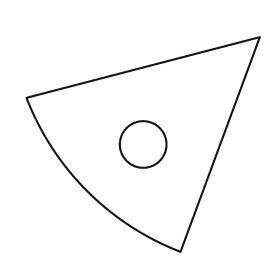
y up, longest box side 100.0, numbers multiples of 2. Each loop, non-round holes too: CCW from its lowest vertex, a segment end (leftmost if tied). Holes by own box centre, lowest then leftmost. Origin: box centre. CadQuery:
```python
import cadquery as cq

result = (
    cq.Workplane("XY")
    .moveTo(16.0, -46.0)
    .lineTo(50.0, 46.0)
    .lineTo(-50.0, 20.0)
    .threePointArc((-24.0, -20.0), (16.0, -46.0))
    .close()
    .moveTo(0.0, 0.0)
    .circle(10.0)
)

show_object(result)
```